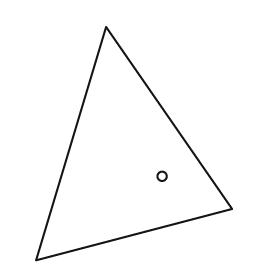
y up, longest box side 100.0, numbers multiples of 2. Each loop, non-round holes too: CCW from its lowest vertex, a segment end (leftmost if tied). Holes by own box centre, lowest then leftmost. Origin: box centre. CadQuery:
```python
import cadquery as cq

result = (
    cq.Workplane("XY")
    .moveTo(-42.0, -50.0)
    .lineTo(42.0, -28.0)
    .lineTo(-12.0, 50.0)
    .close()
    .moveTo(12.0, -14.0)
    .circle(2.0)
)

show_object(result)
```